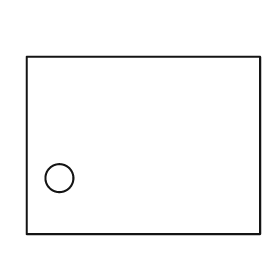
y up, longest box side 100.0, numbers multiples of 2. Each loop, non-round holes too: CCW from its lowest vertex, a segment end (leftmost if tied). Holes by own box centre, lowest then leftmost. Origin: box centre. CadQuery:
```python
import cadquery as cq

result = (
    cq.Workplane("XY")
    .moveTo(-50.0, -38.0)
    .lineTo(50.0, -38.0)
    .lineTo(50.0, 38.0)
    .lineTo(-50.0, 38.0)
    .close()
    .moveTo(-36.0, -14.0)
    .circle(6.0)
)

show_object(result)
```